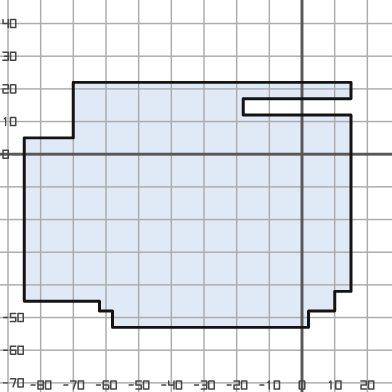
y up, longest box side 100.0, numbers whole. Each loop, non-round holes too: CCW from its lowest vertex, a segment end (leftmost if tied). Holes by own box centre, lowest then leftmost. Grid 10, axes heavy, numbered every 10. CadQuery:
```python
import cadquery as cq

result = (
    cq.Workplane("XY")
    .moveTo(-58.0, -53.0)
    .lineTo(2.0, -53.0)
    .lineTo(2.0, -48.0)
    .lineTo(10.0, -48.0)
    .lineTo(10.0, -42.0)
    .lineTo(15.0, -42.0)
    .lineTo(15.0, 12.0)
    .lineTo(-18.0, 12.0)
    .lineTo(-18.0, 17.0)
    .lineTo(15.0, 17.0)
    .lineTo(15.0, 22.0)
    .lineTo(-70.0, 22.0)
    .lineTo(-70.0, 5.0)
    .lineTo(-85.0, 5.0)
    .lineTo(-85.0, -45.0)
    .lineTo(-62.0, -45.0)
    .lineTo(-62.0, -48.0)
    .lineTo(-58.0, -48.0)
    .close()
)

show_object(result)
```